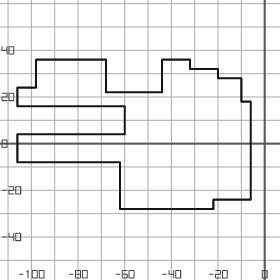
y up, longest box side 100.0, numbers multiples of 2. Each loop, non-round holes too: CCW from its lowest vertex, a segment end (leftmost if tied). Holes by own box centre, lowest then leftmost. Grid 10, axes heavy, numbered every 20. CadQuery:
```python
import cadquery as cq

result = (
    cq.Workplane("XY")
    .moveTo(-62.0, -28.0)
    .lineTo(-22.0, -28.0)
    .lineTo(-22.0, -24.0)
    .lineTo(-6.0, -24.0)
    .lineTo(-6.0, 18.0)
    .lineTo(-10.0, 18.0)
    .lineTo(-10.0, 28.0)
    .lineTo(-20.0, 28.0)
    .lineTo(-20.0, 32.0)
    .lineTo(-32.0, 32.0)
    .lineTo(-32.0, 36.0)
    .lineTo(-44.0, 36.0)
    .lineTo(-44.0, 22.0)
    .lineTo(-68.0, 22.0)
    .lineTo(-68.0, 36.0)
    .lineTo(-98.0, 36.0)
    .lineTo(-98.0, 24.0)
    .lineTo(-106.0, 24.0)
    .lineTo(-106.0, 16.0)
    .lineTo(-60.0, 16.0)
    .lineTo(-60.0, 4.0)
    .lineTo(-106.0, 4.0)
    .lineTo(-106.0, -8.0)
    .lineTo(-62.0, -8.0)
    .close()
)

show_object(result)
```